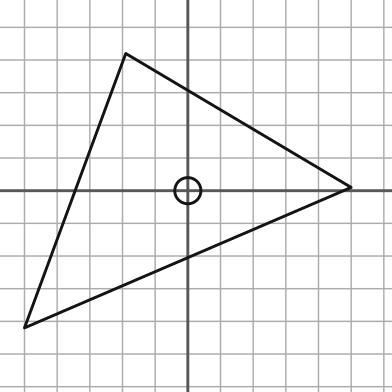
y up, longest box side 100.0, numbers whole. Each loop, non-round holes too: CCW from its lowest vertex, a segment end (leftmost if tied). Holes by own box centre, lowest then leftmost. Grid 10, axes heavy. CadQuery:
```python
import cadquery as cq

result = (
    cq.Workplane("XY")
    .moveTo(-50.0, -42.0)
    .lineTo(50.0, 1.0)
    .lineTo(-19.0, 42.0)
    .close()
    .moveTo(0.0, 0.0)
    .circle(4.0)
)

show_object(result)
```